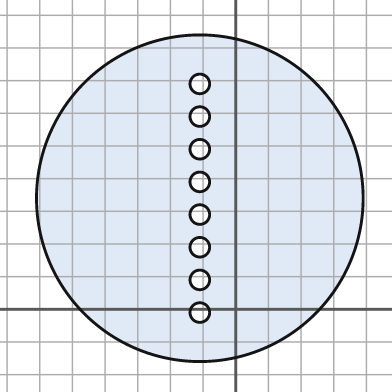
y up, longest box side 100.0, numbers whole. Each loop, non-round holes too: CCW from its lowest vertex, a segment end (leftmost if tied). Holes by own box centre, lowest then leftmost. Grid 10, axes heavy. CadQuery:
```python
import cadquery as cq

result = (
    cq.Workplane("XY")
    .moveTo(-11.0, 34.0)
    .circle(50.0)
    .moveTo(-11.0, -1.0)
    .circle(3.0)
    .moveTo(-11.0, 9.0)
    .circle(3.0)
    .moveTo(-11.0, 19.0)
    .circle(3.0)
    .moveTo(-11.0, 29.0)
    .circle(3.0)
    .moveTo(-11.0, 39.0)
    .circle(3.0)
    .moveTo(-11.0, 49.0)
    .circle(3.0)
    .moveTo(-11.0, 59.0)
    .circle(3.0)
    .moveTo(-11.0, 69.0)
    .circle(3.0)
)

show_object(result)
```